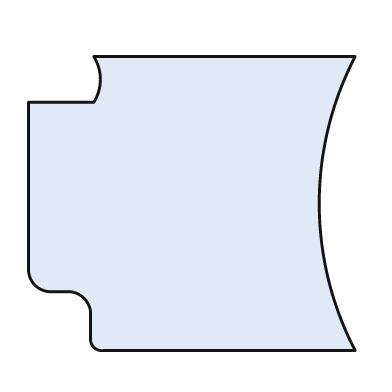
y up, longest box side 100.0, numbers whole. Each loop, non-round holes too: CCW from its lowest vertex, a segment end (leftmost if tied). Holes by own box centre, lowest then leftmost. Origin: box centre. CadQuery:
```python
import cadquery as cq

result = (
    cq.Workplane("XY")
    .moveTo(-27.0, -45.0)
    .lineTo(50.0, -45.0)
    .threePointArc((39.0, 0.0), (50.0, 45.0))
    .lineTo(-30.0, 45.0)
    .threePointArc((-28.0, 38.0), (-30.0, 31.0))
    .lineTo(-50.0, 31.0)
    .lineTo(-50.0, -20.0)
    .threePointArc((-48.0, -25.0), (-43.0, -27.0))
    .lineTo(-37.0, -27.0)
    .threePointArc((-33.0, -29.0), (-31.0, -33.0))
    .lineTo(-31.0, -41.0)
    .threePointArc((-30.0, -44.0), (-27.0, -45.0))
    .close()
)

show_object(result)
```